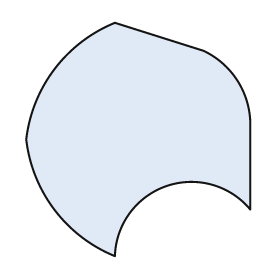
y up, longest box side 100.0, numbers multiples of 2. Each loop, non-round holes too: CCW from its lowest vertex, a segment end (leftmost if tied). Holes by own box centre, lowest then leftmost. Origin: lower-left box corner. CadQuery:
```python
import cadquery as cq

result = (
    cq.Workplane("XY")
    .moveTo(38.0, 0.0)
    .threePointArc((60.0, 30.0), (96.0, 20.0))
    .lineTo(96.0, 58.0)
    .threePointArc((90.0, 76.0), (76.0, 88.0))
    .lineTo(38.0, 100.0)
    .threePointArc((12.0, 80.0), (0.0, 50.0))
    .threePointArc((12.0, 20.0), (38.0, 0.0))
    .close()
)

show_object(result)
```